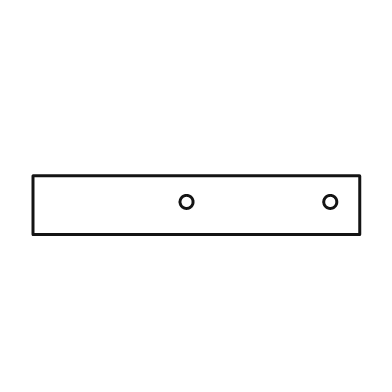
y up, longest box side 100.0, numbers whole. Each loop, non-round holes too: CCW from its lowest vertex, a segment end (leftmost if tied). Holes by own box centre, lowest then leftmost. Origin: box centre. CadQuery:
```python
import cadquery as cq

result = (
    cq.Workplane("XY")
    .moveTo(-50.0, -9.0)
    .lineTo(50.0, -9.0)
    .lineTo(50.0, 9.0)
    .lineTo(-50.0, 9.0)
    .close()
    .moveTo(-3.0, 1.0)
    .circle(2.0)
    .moveTo(41.0, 1.0)
    .circle(2.0)
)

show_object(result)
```